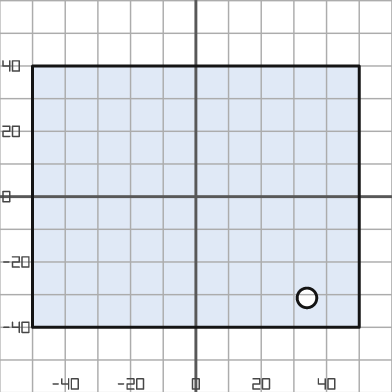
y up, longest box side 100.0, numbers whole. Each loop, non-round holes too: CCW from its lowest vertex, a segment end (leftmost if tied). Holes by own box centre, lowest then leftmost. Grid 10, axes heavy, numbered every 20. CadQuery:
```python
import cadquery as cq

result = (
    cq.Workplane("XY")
    .moveTo(-50.0, -40.0)
    .lineTo(50.0, -40.0)
    .lineTo(50.0, 40.0)
    .lineTo(-50.0, 40.0)
    .close()
    .moveTo(34.0, -31.0)
    .circle(3.0)
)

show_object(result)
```